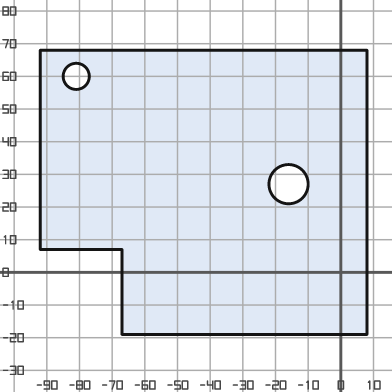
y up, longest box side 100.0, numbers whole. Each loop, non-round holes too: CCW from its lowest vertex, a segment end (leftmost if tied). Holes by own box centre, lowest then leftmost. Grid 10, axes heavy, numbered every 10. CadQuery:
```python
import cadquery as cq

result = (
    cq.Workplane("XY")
    .moveTo(-67.0, -19.0)
    .lineTo(8.0, -19.0)
    .lineTo(8.0, 68.0)
    .lineTo(-92.0, 68.0)
    .lineTo(-92.0, 7.0)
    .lineTo(-67.0, 7.0)
    .close()
    .moveTo(-16.0, 27.0)
    .circle(6.0)
    .moveTo(-81.0, 60.0)
    .circle(4.0)
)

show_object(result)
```